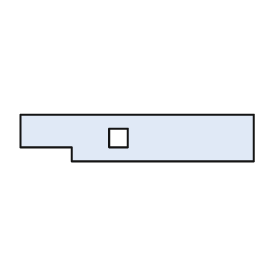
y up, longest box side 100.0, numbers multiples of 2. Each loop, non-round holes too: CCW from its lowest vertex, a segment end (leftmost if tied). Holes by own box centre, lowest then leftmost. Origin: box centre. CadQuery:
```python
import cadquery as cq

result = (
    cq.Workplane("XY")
    .moveTo(-28.0, -10.0)
    .lineTo(50.0, -10.0)
    .lineTo(50.0, 10.0)
    .lineTo(-50.0, 10.0)
    .lineTo(-50.0, -4.0)
    .lineTo(-28.0, -4.0)
    .close()
    .moveTo(-12.0, -4.0)
    .lineTo(-4.0, -4.0)
    .lineTo(-4.0, 4.0)
    .lineTo(-12.0, 4.0)
    .close()
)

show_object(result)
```